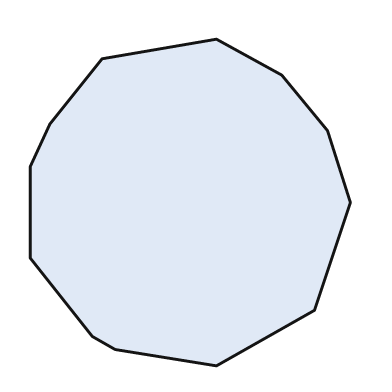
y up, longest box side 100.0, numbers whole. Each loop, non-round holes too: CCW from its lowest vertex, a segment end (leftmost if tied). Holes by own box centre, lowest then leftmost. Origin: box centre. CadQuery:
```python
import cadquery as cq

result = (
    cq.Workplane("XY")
    .moveTo(8.0, -50.0)
    .lineTo(38.0, -33.0)
    .lineTo(49.0, 0.0)
    .lineTo(42.0, 22.0)
    .lineTo(28.0, 39.0)
    .lineTo(8.0, 50.0)
    .lineTo(-27.0, 44.0)
    .lineTo(-43.0, 24.0)
    .lineTo(-49.0, 11.0)
    .lineTo(-49.0, -17.0)
    .lineTo(-30.0, -41.0)
    .lineTo(-23.0, -45.0)
    .close()
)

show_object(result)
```